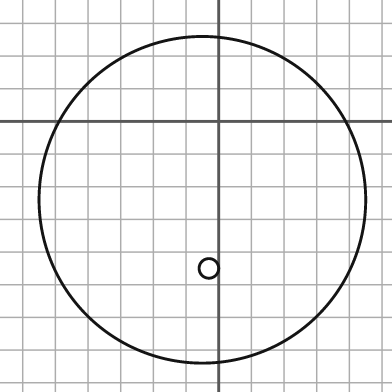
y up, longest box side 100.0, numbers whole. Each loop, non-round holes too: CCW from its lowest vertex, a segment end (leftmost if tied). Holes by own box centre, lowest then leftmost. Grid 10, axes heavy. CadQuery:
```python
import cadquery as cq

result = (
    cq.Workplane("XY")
    .moveTo(-5.0, -24.0)
    .circle(50.0)
    .moveTo(-3.0, -45.0)
    .circle(3.0)
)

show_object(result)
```